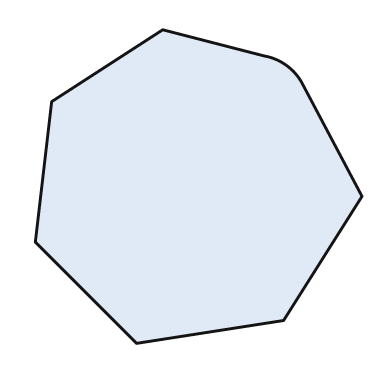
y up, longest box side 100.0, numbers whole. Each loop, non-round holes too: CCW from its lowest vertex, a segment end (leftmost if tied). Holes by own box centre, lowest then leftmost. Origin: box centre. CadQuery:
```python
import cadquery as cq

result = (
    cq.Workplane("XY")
    .moveTo(-19.0, -48.0)
    .lineTo(26.0, -41.0)
    .lineTo(50.0, -3.0)
    .lineTo(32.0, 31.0)
    .threePointArc((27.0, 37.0), (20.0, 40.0))
    .lineTo(-11.0, 48.0)
    .lineTo(-45.0, 26.0)
    .lineTo(-50.0, -17.0)
    .close()
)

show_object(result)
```